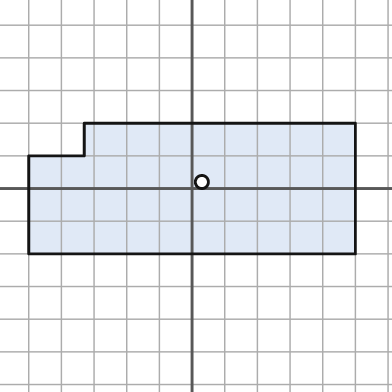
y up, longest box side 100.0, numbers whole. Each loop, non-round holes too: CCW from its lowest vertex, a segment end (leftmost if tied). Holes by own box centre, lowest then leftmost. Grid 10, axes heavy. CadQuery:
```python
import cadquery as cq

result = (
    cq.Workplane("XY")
    .moveTo(-50.0, -20.0)
    .lineTo(50.0, -20.0)
    .lineTo(50.0, 20.0)
    .lineTo(-33.0, 20.0)
    .lineTo(-33.0, 10.0)
    .lineTo(-50.0, 10.0)
    .close()
    .moveTo(3.0, 2.0)
    .circle(2.0)
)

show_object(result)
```